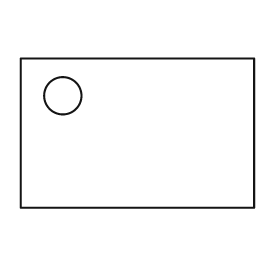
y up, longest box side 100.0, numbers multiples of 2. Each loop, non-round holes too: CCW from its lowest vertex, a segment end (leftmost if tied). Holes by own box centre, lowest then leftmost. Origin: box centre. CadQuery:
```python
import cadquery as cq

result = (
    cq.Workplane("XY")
    .moveTo(-50.0, -32.0)
    .lineTo(50.0, -32.0)
    .lineTo(50.0, 32.0)
    .lineTo(-50.0, 32.0)
    .close()
    .moveTo(-32.0, 16.0)
    .circle(8.0)
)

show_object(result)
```